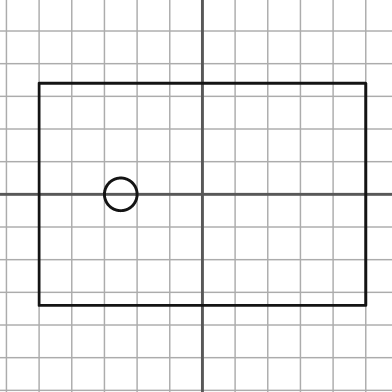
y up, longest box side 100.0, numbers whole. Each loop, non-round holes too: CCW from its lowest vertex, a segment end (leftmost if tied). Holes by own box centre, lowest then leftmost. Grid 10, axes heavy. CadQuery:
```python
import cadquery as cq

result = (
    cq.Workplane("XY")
    .moveTo(-50.0, -34.0)
    .lineTo(50.0, -34.0)
    .lineTo(50.0, 34.0)
    .lineTo(-50.0, 34.0)
    .close()
    .moveTo(-25.0, 0.0)
    .circle(5.0)
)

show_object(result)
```